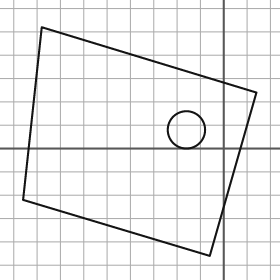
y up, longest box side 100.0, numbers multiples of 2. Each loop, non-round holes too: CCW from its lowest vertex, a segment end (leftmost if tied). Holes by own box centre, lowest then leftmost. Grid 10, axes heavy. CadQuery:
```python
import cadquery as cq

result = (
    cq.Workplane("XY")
    .moveTo(-6.0, -46.0)
    .lineTo(14.0, 24.0)
    .lineTo(-78.0, 52.0)
    .lineTo(-86.0, -22.0)
    .close()
    .moveTo(-16.0, 8.0)
    .circle(8.0)
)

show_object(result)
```